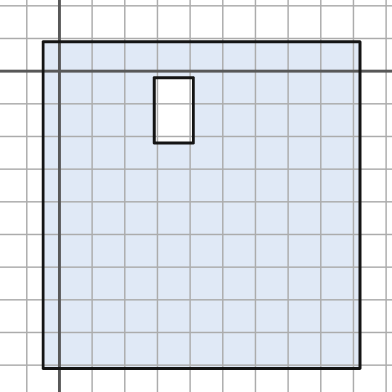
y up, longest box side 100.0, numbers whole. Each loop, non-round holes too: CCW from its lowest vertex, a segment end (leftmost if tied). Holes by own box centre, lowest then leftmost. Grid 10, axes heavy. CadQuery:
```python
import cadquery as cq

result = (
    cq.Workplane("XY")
    .moveTo(-5.0, -91.0)
    .lineTo(92.0, -91.0)
    .lineTo(92.0, 9.0)
    .lineTo(-5.0, 9.0)
    .close()
    .moveTo(29.0, -22.0)
    .lineTo(41.0, -22.0)
    .lineTo(41.0, -2.0)
    .lineTo(29.0, -2.0)
    .close()
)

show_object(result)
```